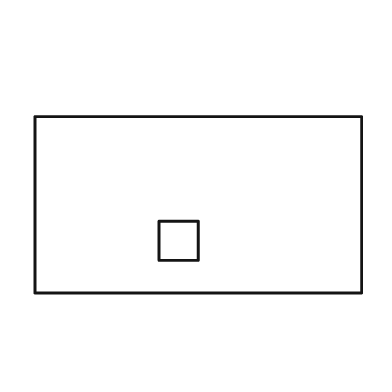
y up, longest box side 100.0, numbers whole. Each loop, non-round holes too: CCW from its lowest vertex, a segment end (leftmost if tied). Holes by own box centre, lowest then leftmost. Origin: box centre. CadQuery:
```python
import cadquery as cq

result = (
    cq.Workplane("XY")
    .moveTo(-50.0, -27.0)
    .lineTo(50.0, -27.0)
    .lineTo(50.0, 27.0)
    .lineTo(-50.0, 27.0)
    .close()
    .moveTo(-12.0, -17.0)
    .lineTo(0.0, -17.0)
    .lineTo(0.0, -5.0)
    .lineTo(-12.0, -5.0)
    .close()
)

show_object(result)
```